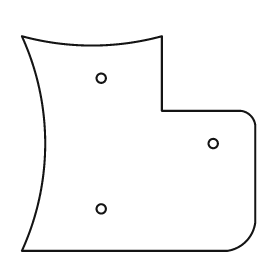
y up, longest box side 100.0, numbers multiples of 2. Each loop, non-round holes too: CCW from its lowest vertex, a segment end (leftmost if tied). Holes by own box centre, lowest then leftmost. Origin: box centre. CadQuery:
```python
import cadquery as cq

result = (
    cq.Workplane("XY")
    .moveTo(-50.0, -46.0)
    .lineTo(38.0, -46.0)
    .threePointArc((46.0, -42.0), (50.0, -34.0))
    .lineTo(50.0, 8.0)
    .threePointArc((48.0, 12.0), (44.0, 14.0))
    .lineTo(10.0, 14.0)
    .lineTo(10.0, 46.0)
    .threePointArc((-20.0, 42.0), (-50.0, 46.0))
    .threePointArc((-40.0, 0.0), (-50.0, -46.0))
    .close()
    .moveTo(-16.0, -28.0)
    .circle(2.0)
    .moveTo(32.0, 0.0)
    .circle(2.0)
    .moveTo(-16.0, 28.0)
    .circle(2.0)
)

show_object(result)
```